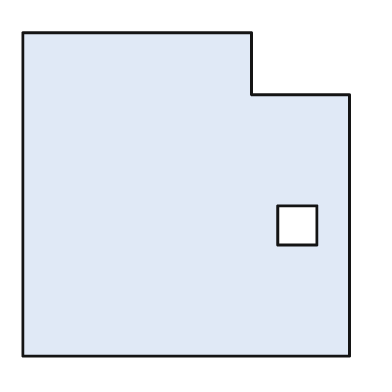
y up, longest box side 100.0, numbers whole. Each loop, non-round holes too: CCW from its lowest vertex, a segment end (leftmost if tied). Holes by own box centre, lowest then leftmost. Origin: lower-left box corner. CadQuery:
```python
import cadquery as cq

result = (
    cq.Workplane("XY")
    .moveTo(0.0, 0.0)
    .lineTo(100.0, 0.0)
    .lineTo(100.0, 80.0)
    .lineTo(70.0, 80.0)
    .lineTo(70.0, 99.0)
    .lineTo(0.0, 99.0)
    .close()
    .moveTo(78.0, 34.0)
    .lineTo(90.0, 34.0)
    .lineTo(90.0, 46.0)
    .lineTo(78.0, 46.0)
    .close()
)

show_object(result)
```